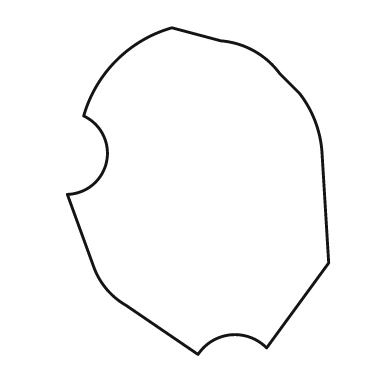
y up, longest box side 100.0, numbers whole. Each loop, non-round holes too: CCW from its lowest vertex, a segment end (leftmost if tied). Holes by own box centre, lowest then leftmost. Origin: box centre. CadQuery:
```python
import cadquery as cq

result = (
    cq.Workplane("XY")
    .moveTo(0.0, -50.0)
    .threePointArc((10.0, -44.0), (21.0, -48.0))
    .lineTo(40.0, -22.0)
    .lineTo(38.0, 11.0)
    .threePointArc((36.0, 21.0), (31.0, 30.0))
    .lineTo(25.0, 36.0)
    .threePointArc((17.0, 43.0), (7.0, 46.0))
    .lineTo(-8.0, 50.0)
    .threePointArc((-25.0, 40.0), (-35.0, 23.0))
    .threePointArc((-28.0, 9.0), (-40.0, -1.0))
    .lineTo(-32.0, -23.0)
    .threePointArc((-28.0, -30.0), (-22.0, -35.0))
    .close()
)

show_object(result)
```